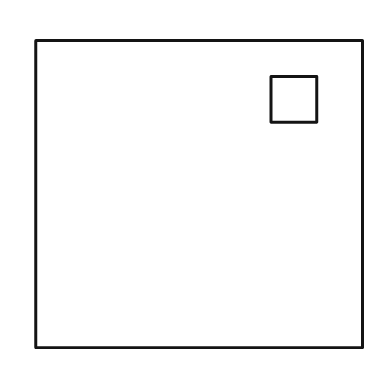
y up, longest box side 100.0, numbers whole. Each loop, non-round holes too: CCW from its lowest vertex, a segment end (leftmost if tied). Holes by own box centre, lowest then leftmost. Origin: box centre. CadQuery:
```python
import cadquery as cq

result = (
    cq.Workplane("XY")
    .moveTo(-50.0, -47.0)
    .lineTo(50.0, -47.0)
    .lineTo(50.0, 47.0)
    .lineTo(-50.0, 47.0)
    .close()
    .moveTo(22.0, 22.0)
    .lineTo(36.0, 22.0)
    .lineTo(36.0, 36.0)
    .lineTo(22.0, 36.0)
    .close()
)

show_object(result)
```